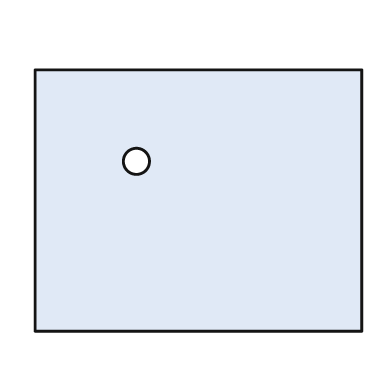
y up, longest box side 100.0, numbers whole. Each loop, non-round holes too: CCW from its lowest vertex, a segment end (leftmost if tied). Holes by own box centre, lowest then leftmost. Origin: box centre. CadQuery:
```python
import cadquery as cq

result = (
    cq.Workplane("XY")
    .moveTo(-50.0, -40.0)
    .lineTo(50.0, -40.0)
    .lineTo(50.0, 40.0)
    .lineTo(-50.0, 40.0)
    .close()
    .moveTo(-19.0, 12.0)
    .circle(4.0)
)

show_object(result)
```